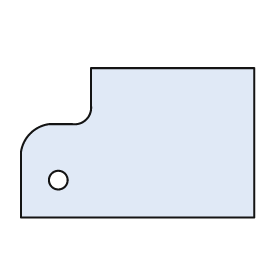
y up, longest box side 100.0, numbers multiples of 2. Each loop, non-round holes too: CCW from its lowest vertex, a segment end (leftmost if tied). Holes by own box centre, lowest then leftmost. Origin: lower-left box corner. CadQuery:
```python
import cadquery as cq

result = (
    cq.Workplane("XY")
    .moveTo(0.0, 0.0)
    .lineTo(100.0, 0.0)
    .lineTo(100.0, 64.0)
    .lineTo(30.0, 64.0)
    .lineTo(30.0, 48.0)
    .threePointArc((28.0, 42.0), (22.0, 40.0))
    .lineTo(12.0, 40.0)
    .threePointArc((4.0, 36.0), (0.0, 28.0))
    .close()
    .moveTo(16.0, 16.0)
    .circle(4.0)
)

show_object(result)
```